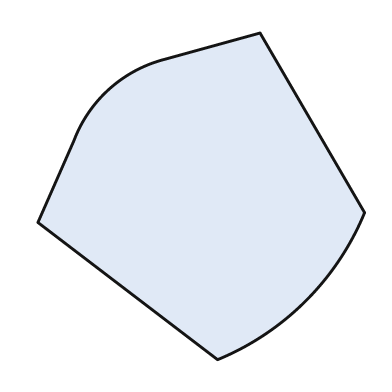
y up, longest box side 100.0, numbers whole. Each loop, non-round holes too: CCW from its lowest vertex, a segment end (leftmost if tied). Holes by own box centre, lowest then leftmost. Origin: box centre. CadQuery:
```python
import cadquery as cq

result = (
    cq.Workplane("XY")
    .moveTo(5.0, -50.0)
    .threePointArc((32.0, -32.0), (50.0, -5.0))
    .lineTo(18.0, 50.0)
    .lineTo(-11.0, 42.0)
    .threePointArc((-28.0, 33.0), (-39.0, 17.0))
    .lineTo(-50.0, -8.0)
    .close()
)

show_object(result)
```